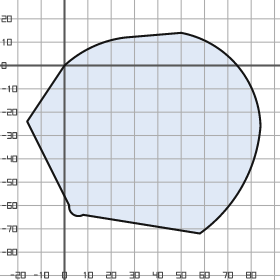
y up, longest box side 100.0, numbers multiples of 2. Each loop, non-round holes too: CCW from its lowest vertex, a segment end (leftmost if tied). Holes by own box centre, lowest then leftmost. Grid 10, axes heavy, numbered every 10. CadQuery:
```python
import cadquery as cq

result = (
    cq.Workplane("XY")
    .moveTo(58.0, -72.0)
    .threePointArc((76.0, -52.0), (84.0, -26.0))
    .threePointArc((74.0, 0.0), (50.0, 14.0))
    .lineTo(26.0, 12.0)
    .threePointArc((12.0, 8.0), (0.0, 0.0))
    .lineTo(-16.0, -24.0)
    .lineTo(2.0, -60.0)
    .threePointArc((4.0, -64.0), (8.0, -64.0))
    .close()
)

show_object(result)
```